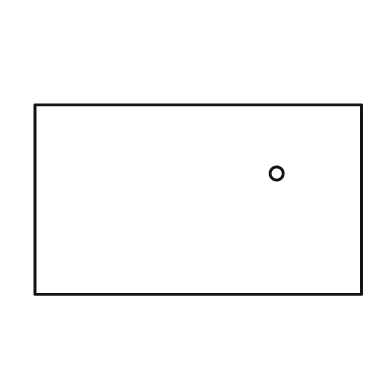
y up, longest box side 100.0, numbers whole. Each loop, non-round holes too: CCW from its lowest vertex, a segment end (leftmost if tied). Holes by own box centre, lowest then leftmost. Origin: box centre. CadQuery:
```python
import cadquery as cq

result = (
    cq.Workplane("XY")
    .moveTo(-50.0, -29.0)
    .lineTo(50.0, -29.0)
    .lineTo(50.0, 29.0)
    .lineTo(-50.0, 29.0)
    .close()
    .moveTo(24.0, 8.0)
    .circle(2.0)
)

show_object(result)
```